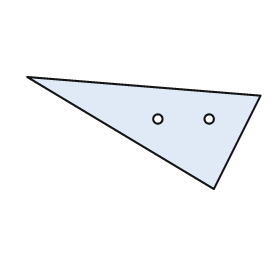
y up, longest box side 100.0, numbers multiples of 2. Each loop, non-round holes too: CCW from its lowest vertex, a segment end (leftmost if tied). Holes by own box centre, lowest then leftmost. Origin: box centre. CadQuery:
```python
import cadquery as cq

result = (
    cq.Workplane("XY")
    .moveTo(30.0, -24.0)
    .lineTo(50.0, 16.0)
    .lineTo(-50.0, 24.0)
    .close()
    .moveTo(6.0, 6.0)
    .circle(2.0)
    .moveTo(28.0, 6.0)
    .circle(2.0)
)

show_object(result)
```